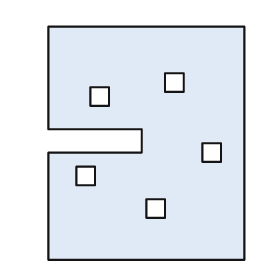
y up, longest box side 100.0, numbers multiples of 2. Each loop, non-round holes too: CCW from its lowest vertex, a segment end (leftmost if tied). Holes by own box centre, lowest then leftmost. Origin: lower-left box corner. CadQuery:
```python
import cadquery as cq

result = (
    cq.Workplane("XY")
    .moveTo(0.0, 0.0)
    .lineTo(84.0, 0.0)
    .lineTo(84.0, 100.0)
    .lineTo(0.0, 100.0)
    .lineTo(0.0, 56.0)
    .lineTo(40.0, 56.0)
    .lineTo(40.0, 46.0)
    .lineTo(0.0, 46.0)
    .close()
    .moveTo(42.0, 18.0)
    .lineTo(50.0, 18.0)
    .lineTo(50.0, 26.0)
    .lineTo(42.0, 26.0)
    .close()
    .moveTo(12.0, 32.0)
    .lineTo(20.0, 32.0)
    .lineTo(20.0, 40.0)
    .lineTo(12.0, 40.0)
    .close()
    .moveTo(66.0, 42.0)
    .lineTo(74.0, 42.0)
    .lineTo(74.0, 50.0)
    .lineTo(66.0, 50.0)
    .close()
    .moveTo(18.0, 66.0)
    .lineTo(26.0, 66.0)
    .lineTo(26.0, 74.0)
    .lineTo(18.0, 74.0)
    .close()
    .moveTo(50.0, 72.0)
    .lineTo(58.0, 72.0)
    .lineTo(58.0, 80.0)
    .lineTo(50.0, 80.0)
    .close()
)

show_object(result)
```